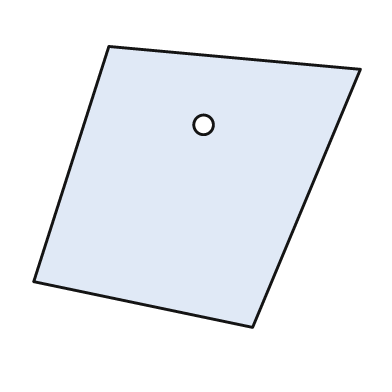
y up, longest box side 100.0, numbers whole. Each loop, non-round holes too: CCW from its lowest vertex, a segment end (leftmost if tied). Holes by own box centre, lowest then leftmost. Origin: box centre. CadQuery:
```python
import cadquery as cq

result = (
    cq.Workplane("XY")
    .moveTo(17.0, -43.0)
    .lineTo(50.0, 36.0)
    .lineTo(-27.0, 43.0)
    .lineTo(-50.0, -29.0)
    .close()
    .moveTo(2.0, 19.0)
    .circle(3.0)
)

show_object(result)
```